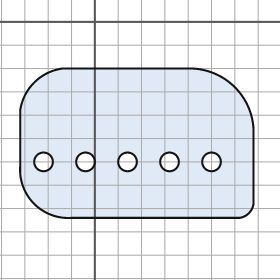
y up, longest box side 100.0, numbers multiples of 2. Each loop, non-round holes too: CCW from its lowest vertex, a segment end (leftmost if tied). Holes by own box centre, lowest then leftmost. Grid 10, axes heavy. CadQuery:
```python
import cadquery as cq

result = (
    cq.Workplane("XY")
    .moveTo(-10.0, -84.0)
    .lineTo(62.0, -84.0)
    .threePointArc((66.0, -82.0), (68.0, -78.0))
    .lineTo(68.0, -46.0)
    .threePointArc((60.0, -28.0), (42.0, -20.0))
    .lineTo(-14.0, -20.0)
    .threePointArc((-26.0, -26.0), (-32.0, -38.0))
    .lineTo(-32.0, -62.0)
    .threePointArc((-26.0, -78.0), (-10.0, -84.0))
    .close()
    .moveTo(-22.0, -60.0)
    .circle(4.0)
    .moveTo(-4.0, -60.0)
    .circle(4.0)
    .moveTo(14.0, -60.0)
    .circle(4.0)
    .moveTo(32.0, -60.0)
    .circle(4.0)
    .moveTo(50.0, -60.0)
    .circle(4.0)
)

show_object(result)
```